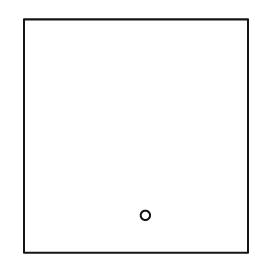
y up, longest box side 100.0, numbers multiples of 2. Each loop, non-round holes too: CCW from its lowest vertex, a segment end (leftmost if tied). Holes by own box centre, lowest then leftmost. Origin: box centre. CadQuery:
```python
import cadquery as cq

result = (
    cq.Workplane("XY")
    .moveTo(-48.0, -50.0)
    .lineTo(48.0, -50.0)
    .lineTo(48.0, 50.0)
    .lineTo(-48.0, 50.0)
    .close()
    .moveTo(4.0, -34.0)
    .circle(2.0)
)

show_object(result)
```